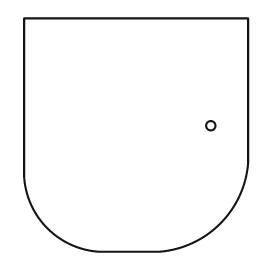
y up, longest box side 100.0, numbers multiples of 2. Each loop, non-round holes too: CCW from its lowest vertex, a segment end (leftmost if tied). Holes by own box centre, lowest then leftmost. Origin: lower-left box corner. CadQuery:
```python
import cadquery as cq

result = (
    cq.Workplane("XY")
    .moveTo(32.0, 0.0)
    .lineTo(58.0, 0.0)
    .threePointArc((84.0, 12.0), (96.0, 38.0))
    .lineTo(96.0, 100.0)
    .lineTo(0.0, 100.0)
    .lineTo(0.0, 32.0)
    .threePointArc((10.0, 10.0), (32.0, 0.0))
    .close()
    .moveTo(80.0, 54.0)
    .circle(2.0)
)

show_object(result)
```